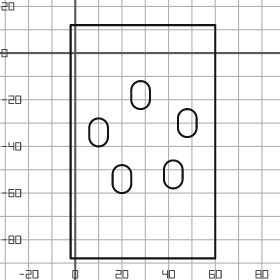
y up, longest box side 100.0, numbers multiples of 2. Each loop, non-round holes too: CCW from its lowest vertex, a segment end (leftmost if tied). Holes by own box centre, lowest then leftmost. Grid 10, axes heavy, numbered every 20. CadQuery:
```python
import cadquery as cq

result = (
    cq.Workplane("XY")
    .moveTo(-2.0, -88.0)
    .lineTo(60.0, -88.0)
    .lineTo(60.0, 12.0)
    .lineTo(-2.0, 12.0)
    .close()
    .moveTo(16.0, -56.0)
    .threePointArc((20.0, -60.0), (24.0, -56.0))
    .lineTo(24.0, -52.0)
    .threePointArc((20.0, -48.0), (16.0, -52.0))
    .close()
    .moveTo(38.0, -54.0)
    .threePointArc((42.0, -58.0), (46.0, -54.0))
    .lineTo(46.0, -50.0)
    .threePointArc((42.0, -46.0), (38.0, -50.0))
    .close()
    .moveTo(6.0, -36.0)
    .threePointArc((10.0, -40.0), (14.0, -36.0))
    .lineTo(14.0, -32.0)
    .threePointArc((10.0, -28.0), (6.0, -32.0))
    .close()
    .moveTo(44.0, -32.0)
    .threePointArc((48.0, -36.0), (52.0, -32.0))
    .lineTo(52.0, -28.0)
    .threePointArc((48.0, -24.0), (44.0, -28.0))
    .close()
    .moveTo(24.0, -20.0)
    .threePointArc((28.0, -24.0), (32.0, -20.0))
    .lineTo(32.0, -16.0)
    .threePointArc((28.0, -12.0), (24.0, -16.0))
    .close()
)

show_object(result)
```